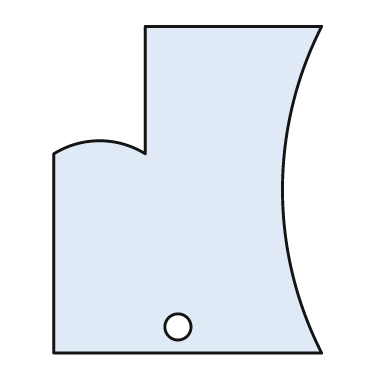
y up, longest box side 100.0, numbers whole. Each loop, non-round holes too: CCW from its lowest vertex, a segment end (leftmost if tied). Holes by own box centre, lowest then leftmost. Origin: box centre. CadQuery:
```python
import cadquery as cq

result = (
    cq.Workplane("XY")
    .moveTo(-41.0, -50.0)
    .lineTo(41.0, -50.0)
    .threePointArc((29.0, 0.0), (41.0, 50.0))
    .lineTo(-13.0, 50.0)
    .lineTo(-13.0, 11.0)
    .threePointArc((-27.0, 15.0), (-41.0, 11.0))
    .close()
    .moveTo(-3.0, -42.0)
    .circle(4.0)
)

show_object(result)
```